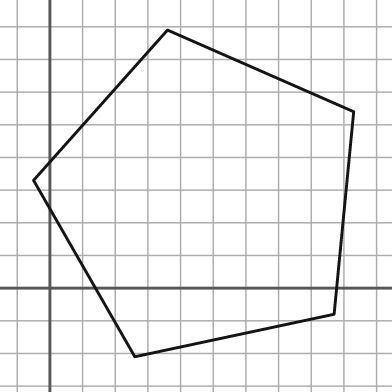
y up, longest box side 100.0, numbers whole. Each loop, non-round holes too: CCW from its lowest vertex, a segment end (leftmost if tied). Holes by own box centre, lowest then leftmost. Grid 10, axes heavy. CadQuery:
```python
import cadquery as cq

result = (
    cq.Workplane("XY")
    .moveTo(26.0, -21.0)
    .lineTo(87.0, -8.0)
    .lineTo(93.0, 54.0)
    .lineTo(36.0, 79.0)
    .lineTo(-5.0, 33.0)
    .close()
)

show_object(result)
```